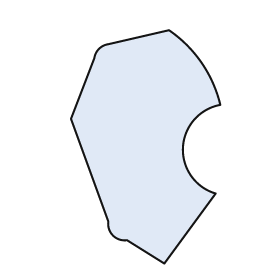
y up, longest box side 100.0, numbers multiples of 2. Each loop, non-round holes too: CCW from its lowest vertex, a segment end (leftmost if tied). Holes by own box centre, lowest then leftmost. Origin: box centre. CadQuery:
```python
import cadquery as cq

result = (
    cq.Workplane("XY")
    .moveTo(8.0, -50.0)
    .lineTo(30.0, -20.0)
    .threePointArc((16.0, 0.0), (32.0, 18.0))
    .threePointArc((24.0, 36.0), (10.0, 50.0))
    .lineTo(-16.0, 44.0)
    .threePointArc((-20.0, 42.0), (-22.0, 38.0))
    .lineTo(-32.0, 12.0)
    .lineTo(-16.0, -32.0)
    .threePointArc((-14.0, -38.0), (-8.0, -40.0))
    .close()
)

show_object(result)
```